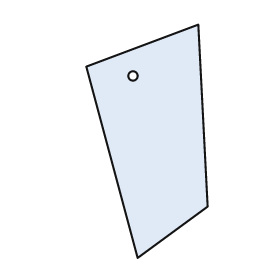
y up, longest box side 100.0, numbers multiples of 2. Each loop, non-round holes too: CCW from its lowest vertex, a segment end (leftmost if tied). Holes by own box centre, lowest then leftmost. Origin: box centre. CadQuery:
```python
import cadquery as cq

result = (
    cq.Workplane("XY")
    .moveTo(-4.0, -50.0)
    .lineTo(26.0, -28.0)
    .lineTo(22.0, 50.0)
    .lineTo(-26.0, 32.0)
    .close()
    .moveTo(-6.0, 28.0)
    .circle(2.0)
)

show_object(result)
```